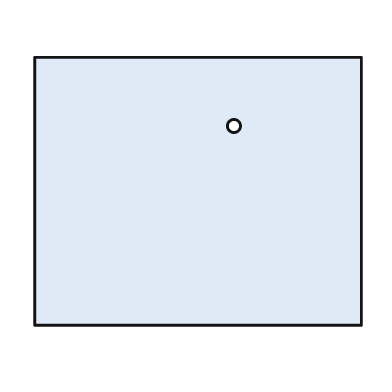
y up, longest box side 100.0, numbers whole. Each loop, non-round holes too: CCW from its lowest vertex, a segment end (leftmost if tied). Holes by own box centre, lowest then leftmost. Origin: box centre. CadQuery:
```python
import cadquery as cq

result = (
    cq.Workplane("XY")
    .moveTo(-50.0, -41.0)
    .lineTo(50.0, -41.0)
    .lineTo(50.0, 41.0)
    .lineTo(-50.0, 41.0)
    .close()
    .moveTo(11.0, 20.0)
    .circle(2.0)
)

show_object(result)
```